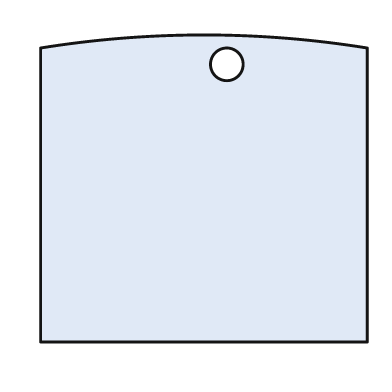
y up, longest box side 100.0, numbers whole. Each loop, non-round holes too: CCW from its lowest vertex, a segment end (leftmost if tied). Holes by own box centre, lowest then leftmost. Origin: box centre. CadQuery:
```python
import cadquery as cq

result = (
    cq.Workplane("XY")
    .moveTo(-50.0, -47.0)
    .lineTo(50.0, -47.0)
    .lineTo(50.0, 43.0)
    .threePointArc((0.0, 47.0), (-50.0, 43.0))
    .close()
    .moveTo(7.0, 38.0)
    .circle(5.0)
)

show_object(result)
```